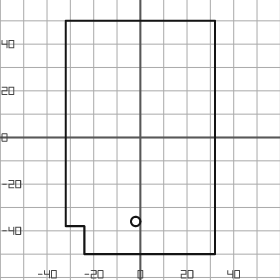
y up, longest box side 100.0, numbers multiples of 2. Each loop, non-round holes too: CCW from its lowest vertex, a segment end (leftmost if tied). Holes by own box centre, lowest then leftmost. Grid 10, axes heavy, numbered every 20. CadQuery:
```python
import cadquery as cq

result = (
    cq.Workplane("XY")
    .moveTo(-24.0, -50.0)
    .lineTo(32.0, -50.0)
    .lineTo(32.0, 50.0)
    .lineTo(-32.0, 50.0)
    .lineTo(-32.0, -38.0)
    .lineTo(-24.0, -38.0)
    .close()
    .moveTo(-2.0, -36.0)
    .circle(2.0)
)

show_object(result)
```